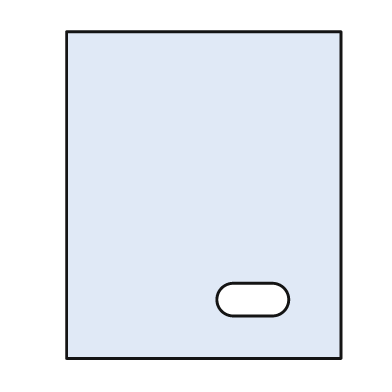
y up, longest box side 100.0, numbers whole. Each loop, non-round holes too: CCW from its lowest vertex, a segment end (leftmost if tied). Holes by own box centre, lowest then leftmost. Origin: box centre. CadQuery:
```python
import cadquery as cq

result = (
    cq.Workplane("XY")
    .moveTo(-42.0, -50.0)
    .lineTo(42.0, -50.0)
    .lineTo(42.0, 50.0)
    .lineTo(-42.0, 50.0)
    .close()
    .moveTo(9.0, -37.0)
    .lineTo(21.0, -37.0)
    .threePointArc((26.0, -32.0), (21.0, -27.0))
    .lineTo(9.0, -27.0)
    .threePointArc((4.0, -32.0), (9.0, -37.0))
    .close()
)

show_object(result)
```